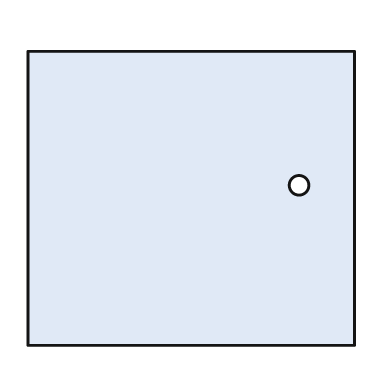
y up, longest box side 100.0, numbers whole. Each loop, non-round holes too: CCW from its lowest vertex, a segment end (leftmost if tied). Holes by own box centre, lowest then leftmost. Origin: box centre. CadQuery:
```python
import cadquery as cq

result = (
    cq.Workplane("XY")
    .moveTo(-50.0, -45.0)
    .lineTo(50.0, -45.0)
    .lineTo(50.0, 45.0)
    .lineTo(-50.0, 45.0)
    .close()
    .moveTo(33.0, 4.0)
    .circle(3.0)
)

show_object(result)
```